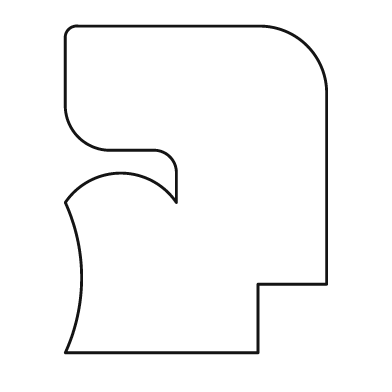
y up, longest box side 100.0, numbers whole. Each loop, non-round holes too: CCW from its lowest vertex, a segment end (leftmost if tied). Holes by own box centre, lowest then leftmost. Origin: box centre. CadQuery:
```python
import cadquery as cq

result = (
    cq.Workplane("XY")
    .moveTo(-40.0, -50.0)
    .lineTo(19.0, -50.0)
    .lineTo(19.0, -29.0)
    .lineTo(40.0, -29.0)
    .lineTo(40.0, 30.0)
    .threePointArc((34.0, 44.0), (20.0, 50.0))
    .lineTo(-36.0, 50.0)
    .threePointArc((-39.0, 49.0), (-40.0, 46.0))
    .lineTo(-40.0, 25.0)
    .threePointArc((-36.0, 16.0), (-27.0, 12.0))
    .lineTo(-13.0, 12.0)
    .threePointArc((-8.0, 10.0), (-6.0, 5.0))
    .lineTo(-6.0, -4.0)
    .threePointArc((-23.0, 5.0), (-40.0, -4.0))
    .threePointArc((-35.0, -27.0), (-40.0, -50.0))
    .close()
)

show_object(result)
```